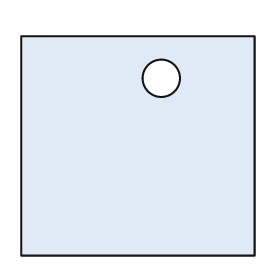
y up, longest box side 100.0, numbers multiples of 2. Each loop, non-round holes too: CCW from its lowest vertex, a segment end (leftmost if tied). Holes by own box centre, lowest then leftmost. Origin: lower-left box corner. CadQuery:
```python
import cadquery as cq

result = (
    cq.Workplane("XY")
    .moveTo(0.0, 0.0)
    .lineTo(100.0, 0.0)
    .lineTo(100.0, 94.0)
    .lineTo(0.0, 94.0)
    .close()
    .moveTo(60.0, 76.0)
    .circle(8.0)
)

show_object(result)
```